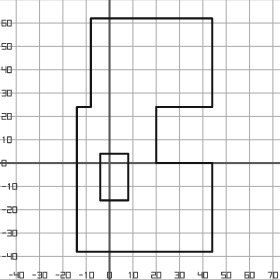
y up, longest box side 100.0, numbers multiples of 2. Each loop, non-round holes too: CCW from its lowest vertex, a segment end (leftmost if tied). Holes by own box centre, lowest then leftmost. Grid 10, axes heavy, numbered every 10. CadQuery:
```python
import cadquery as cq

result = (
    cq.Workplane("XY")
    .moveTo(-14.0, -38.0)
    .lineTo(44.0, -38.0)
    .lineTo(44.0, 0.0)
    .lineTo(20.0, 0.0)
    .lineTo(20.0, 24.0)
    .lineTo(44.0, 24.0)
    .lineTo(44.0, 62.0)
    .lineTo(-8.0, 62.0)
    .lineTo(-8.0, 24.0)
    .lineTo(-14.0, 24.0)
    .close()
    .moveTo(-4.0, -16.0)
    .lineTo(8.0, -16.0)
    .lineTo(8.0, 4.0)
    .lineTo(-4.0, 4.0)
    .close()
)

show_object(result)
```